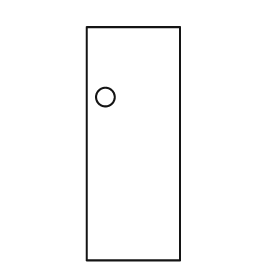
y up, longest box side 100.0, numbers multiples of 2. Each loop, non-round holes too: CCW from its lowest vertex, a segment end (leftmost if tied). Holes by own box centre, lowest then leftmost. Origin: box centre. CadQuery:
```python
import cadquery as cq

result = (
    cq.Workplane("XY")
    .moveTo(-20.0, -50.0)
    .lineTo(20.0, -50.0)
    .lineTo(20.0, 50.0)
    .lineTo(-20.0, 50.0)
    .close()
    .moveTo(-12.0, 20.0)
    .circle(4.0)
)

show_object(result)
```